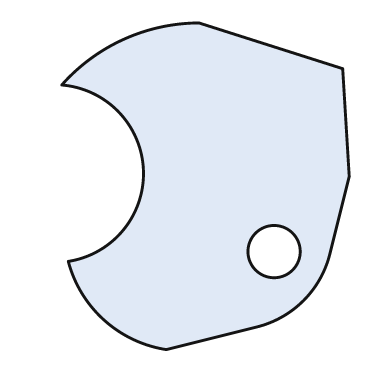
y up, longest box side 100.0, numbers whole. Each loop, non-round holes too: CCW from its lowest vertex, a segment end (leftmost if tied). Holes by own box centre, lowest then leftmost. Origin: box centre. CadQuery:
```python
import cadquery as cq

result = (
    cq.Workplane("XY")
    .moveTo(-12.0, -50.0)
    .lineTo(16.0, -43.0)
    .threePointArc((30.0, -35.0), (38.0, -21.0))
    .lineTo(44.0, 3.0)
    .lineTo(42.0, 36.0)
    .lineTo(-2.0, 50.0)
    .threePointArc((-25.0, 45.0), (-44.0, 31.0))
    .threePointArc((-19.0, 5.0), (-42.0, -23.0))
    .threePointArc((-31.0, -41.0), (-12.0, -50.0))
    .close()
    .moveTo(21.0, -20.0)
    .circle(8.0)
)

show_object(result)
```